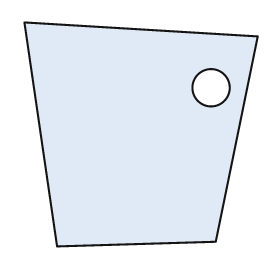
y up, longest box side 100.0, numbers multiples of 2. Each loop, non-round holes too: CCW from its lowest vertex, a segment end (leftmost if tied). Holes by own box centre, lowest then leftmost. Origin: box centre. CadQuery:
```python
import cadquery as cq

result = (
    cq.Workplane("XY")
    .moveTo(-36.0, -48.0)
    .lineTo(32.0, -46.0)
    .lineTo(50.0, 42.0)
    .lineTo(-50.0, 48.0)
    .close()
    .moveTo(30.0, 20.0)
    .circle(8.0)
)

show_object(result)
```